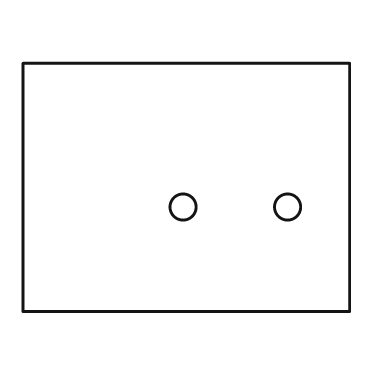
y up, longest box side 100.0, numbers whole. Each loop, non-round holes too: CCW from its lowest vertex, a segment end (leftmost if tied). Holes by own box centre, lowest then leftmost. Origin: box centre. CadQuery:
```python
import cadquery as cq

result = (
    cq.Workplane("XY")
    .moveTo(-50.0, -38.0)
    .lineTo(50.0, -38.0)
    .lineTo(50.0, 38.0)
    .lineTo(-50.0, 38.0)
    .close()
    .moveTo(-1.0, -6.0)
    .circle(4.0)
    .moveTo(31.0, -6.0)
    .circle(4.0)
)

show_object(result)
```